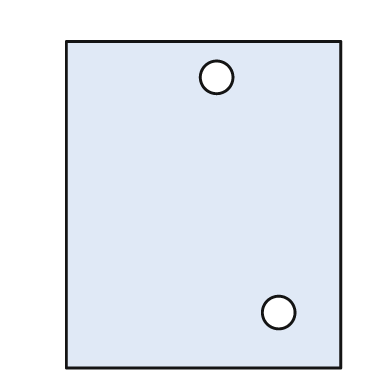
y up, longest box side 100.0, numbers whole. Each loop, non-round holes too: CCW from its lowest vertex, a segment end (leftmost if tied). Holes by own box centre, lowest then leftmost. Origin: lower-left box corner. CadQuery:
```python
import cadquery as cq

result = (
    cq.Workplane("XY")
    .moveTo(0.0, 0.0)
    .lineTo(84.0, 0.0)
    .lineTo(84.0, 100.0)
    .lineTo(0.0, 100.0)
    .close()
    .moveTo(65.0, 17.0)
    .circle(5.0)
    .moveTo(46.0, 89.0)
    .circle(5.0)
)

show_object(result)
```